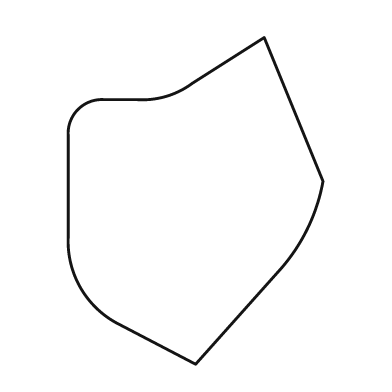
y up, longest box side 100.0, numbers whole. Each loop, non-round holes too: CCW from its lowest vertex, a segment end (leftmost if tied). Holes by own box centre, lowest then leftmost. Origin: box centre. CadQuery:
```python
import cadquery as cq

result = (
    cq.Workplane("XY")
    .moveTo(0.0, -50.0)
    .lineTo(25.0, -22.0)
    .threePointArc((34.0, -9.0), (39.0, 6.0))
    .lineTo(21.0, 50.0)
    .lineTo(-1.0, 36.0)
    .threePointArc((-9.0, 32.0), (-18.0, 31.0))
    .lineTo(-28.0, 31.0)
    .threePointArc((-36.0, 28.0), (-39.0, 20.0))
    .lineTo(-39.0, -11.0)
    .threePointArc((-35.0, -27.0), (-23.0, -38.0))
    .close()
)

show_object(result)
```